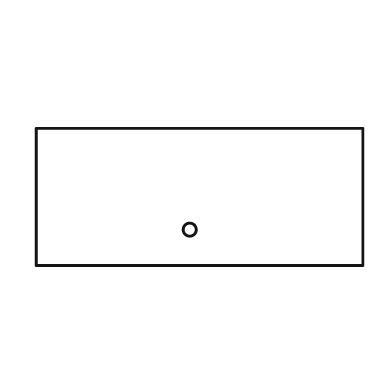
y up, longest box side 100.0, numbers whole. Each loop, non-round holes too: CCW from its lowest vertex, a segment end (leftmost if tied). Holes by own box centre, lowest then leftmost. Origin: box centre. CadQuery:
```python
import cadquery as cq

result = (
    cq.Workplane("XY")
    .moveTo(-50.0, -21.0)
    .lineTo(50.0, -21.0)
    .lineTo(50.0, 21.0)
    .lineTo(-50.0, 21.0)
    .close()
    .moveTo(-3.0, -10.0)
    .circle(2.0)
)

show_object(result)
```